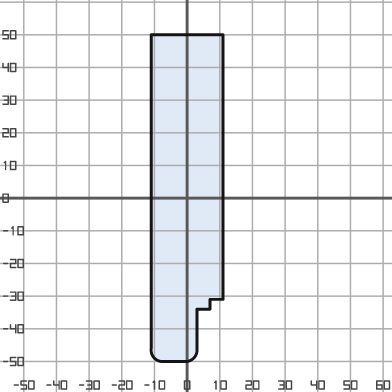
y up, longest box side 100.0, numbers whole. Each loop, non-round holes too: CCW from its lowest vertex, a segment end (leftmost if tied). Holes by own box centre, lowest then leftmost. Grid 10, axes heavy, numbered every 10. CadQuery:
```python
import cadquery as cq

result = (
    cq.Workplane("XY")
    .moveTo(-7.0, -50.0)
    .lineTo(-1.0, -50.0)
    .threePointArc((2.0, -49.0), (3.0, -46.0))
    .lineTo(3.0, -34.0)
    .lineTo(7.0, -34.0)
    .lineTo(7.0, -31.0)
    .lineTo(11.0, -31.0)
    .lineTo(11.0, 50.0)
    .lineTo(-11.0, 50.0)
    .lineTo(-11.0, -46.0)
    .threePointArc((-10.0, -49.0), (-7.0, -50.0))
    .close()
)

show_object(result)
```